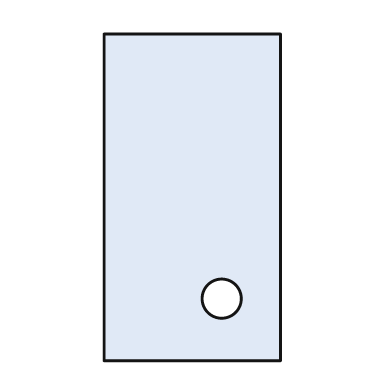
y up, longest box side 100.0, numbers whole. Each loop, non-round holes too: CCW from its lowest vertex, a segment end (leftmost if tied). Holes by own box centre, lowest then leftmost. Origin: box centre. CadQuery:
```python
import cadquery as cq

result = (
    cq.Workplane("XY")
    .moveTo(-27.0, -50.0)
    .lineTo(27.0, -50.0)
    .lineTo(27.0, 50.0)
    .lineTo(-27.0, 50.0)
    .close()
    .moveTo(9.0, -31.0)
    .circle(6.0)
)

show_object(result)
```